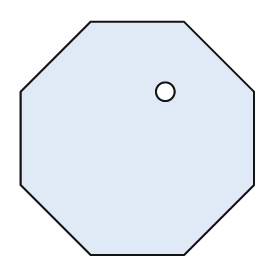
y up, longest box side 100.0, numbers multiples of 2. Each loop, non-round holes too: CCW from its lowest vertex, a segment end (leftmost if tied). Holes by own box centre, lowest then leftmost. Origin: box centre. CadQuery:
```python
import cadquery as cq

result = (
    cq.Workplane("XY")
    .moveTo(-20.0, -50.0)
    .lineTo(20.0, -50.0)
    .lineTo(50.0, -20.0)
    .lineTo(50.0, 20.0)
    .lineTo(20.0, 50.0)
    .lineTo(-20.0, 50.0)
    .lineTo(-50.0, 20.0)
    .lineTo(-50.0, -20.0)
    .close()
    .moveTo(12.0, 20.0)
    .circle(4.0)
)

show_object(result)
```